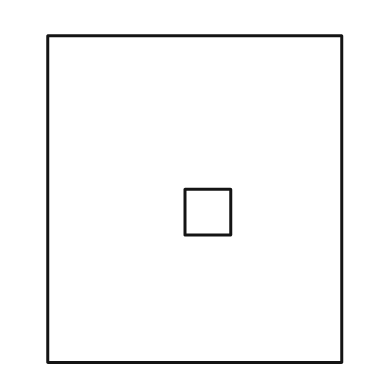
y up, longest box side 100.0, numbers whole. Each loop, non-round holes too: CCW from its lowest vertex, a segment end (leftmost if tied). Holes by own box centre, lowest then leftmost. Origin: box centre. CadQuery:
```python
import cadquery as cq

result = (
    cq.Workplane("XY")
    .moveTo(-45.0, -50.0)
    .lineTo(45.0, -50.0)
    .lineTo(45.0, 50.0)
    .lineTo(-45.0, 50.0)
    .close()
    .moveTo(-3.0, -11.0)
    .lineTo(11.0, -11.0)
    .lineTo(11.0, 3.0)
    .lineTo(-3.0, 3.0)
    .close()
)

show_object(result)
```